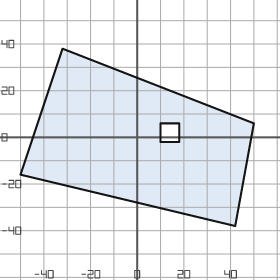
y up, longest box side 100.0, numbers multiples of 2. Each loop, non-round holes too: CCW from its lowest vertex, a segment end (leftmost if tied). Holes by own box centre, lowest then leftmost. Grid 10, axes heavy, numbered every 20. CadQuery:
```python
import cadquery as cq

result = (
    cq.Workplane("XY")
    .moveTo(42.0, -38.0)
    .lineTo(50.0, 6.0)
    .lineTo(-32.0, 38.0)
    .lineTo(-50.0, -16.0)
    .close()
    .moveTo(10.0, -2.0)
    .lineTo(18.0, -2.0)
    .lineTo(18.0, 6.0)
    .lineTo(10.0, 6.0)
    .close()
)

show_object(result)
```